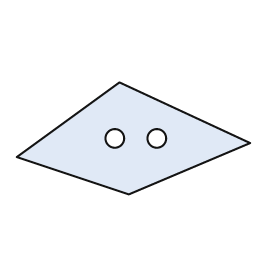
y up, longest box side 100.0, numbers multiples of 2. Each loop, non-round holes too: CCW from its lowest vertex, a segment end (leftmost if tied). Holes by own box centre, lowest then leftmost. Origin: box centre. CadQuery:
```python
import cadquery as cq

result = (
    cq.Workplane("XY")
    .moveTo(-2.0, -24.0)
    .lineTo(50.0, -2.0)
    .lineTo(-6.0, 24.0)
    .lineTo(-50.0, -8.0)
    .close()
    .moveTo(-8.0, 0.0)
    .circle(4.0)
    .moveTo(10.0, 0.0)
    .circle(4.0)
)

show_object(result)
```